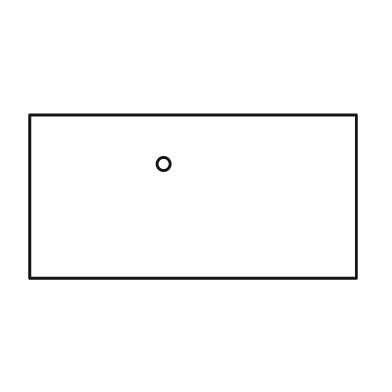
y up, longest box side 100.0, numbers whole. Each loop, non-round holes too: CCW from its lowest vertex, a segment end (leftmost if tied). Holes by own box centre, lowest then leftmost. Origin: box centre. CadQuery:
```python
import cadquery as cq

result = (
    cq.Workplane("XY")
    .moveTo(-50.0, -25.0)
    .lineTo(50.0, -25.0)
    .lineTo(50.0, 25.0)
    .lineTo(-50.0, 25.0)
    .close()
    .moveTo(-9.0, 10.0)
    .circle(2.0)
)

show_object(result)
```